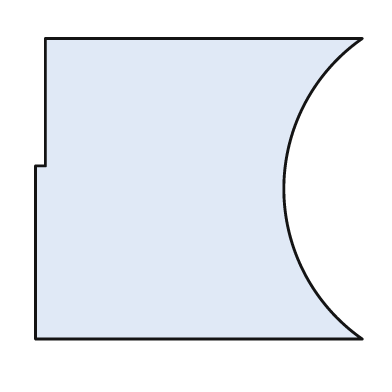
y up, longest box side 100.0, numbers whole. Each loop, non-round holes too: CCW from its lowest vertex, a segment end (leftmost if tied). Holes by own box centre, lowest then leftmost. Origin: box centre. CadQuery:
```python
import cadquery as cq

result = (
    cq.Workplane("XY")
    .moveTo(-50.0, -46.0)
    .lineTo(50.0, -46.0)
    .threePointArc((26.0, 0.0), (50.0, 46.0))
    .lineTo(-47.0, 46.0)
    .lineTo(-47.0, 7.0)
    .lineTo(-50.0, 7.0)
    .close()
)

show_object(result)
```